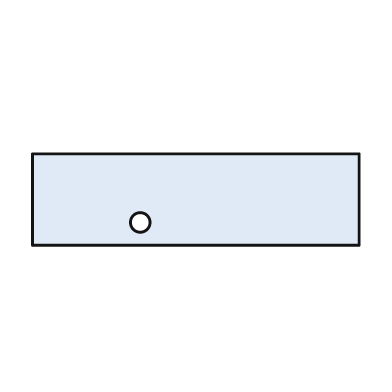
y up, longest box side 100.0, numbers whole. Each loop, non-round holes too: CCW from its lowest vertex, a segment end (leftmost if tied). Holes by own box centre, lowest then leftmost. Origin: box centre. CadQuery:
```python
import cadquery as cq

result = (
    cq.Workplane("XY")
    .moveTo(-50.0, -14.0)
    .lineTo(50.0, -14.0)
    .lineTo(50.0, 14.0)
    .lineTo(-50.0, 14.0)
    .close()
    .moveTo(-17.0, -7.0)
    .circle(3.0)
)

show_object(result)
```